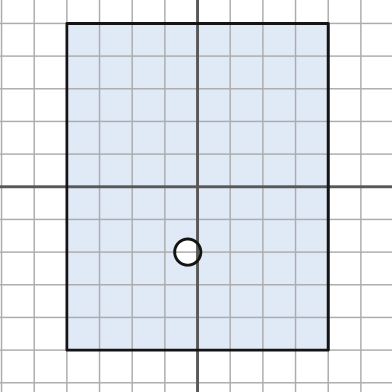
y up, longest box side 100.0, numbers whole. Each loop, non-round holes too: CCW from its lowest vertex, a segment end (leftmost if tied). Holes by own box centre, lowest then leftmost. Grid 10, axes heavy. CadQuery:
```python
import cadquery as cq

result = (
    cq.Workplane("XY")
    .moveTo(-40.0, -50.0)
    .lineTo(40.0, -50.0)
    .lineTo(40.0, 50.0)
    .lineTo(-40.0, 50.0)
    .close()
    .moveTo(-3.0, -20.0)
    .circle(4.0)
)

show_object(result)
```